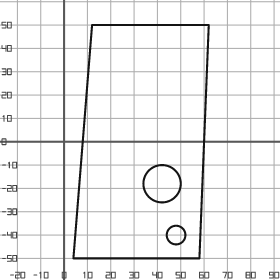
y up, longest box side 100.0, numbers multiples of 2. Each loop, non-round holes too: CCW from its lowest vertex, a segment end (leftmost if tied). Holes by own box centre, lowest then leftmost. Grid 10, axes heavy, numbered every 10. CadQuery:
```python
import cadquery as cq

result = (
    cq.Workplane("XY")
    .moveTo(4.0, -50.0)
    .lineTo(58.0, -50.0)
    .lineTo(62.0, 50.0)
    .lineTo(12.0, 50.0)
    .close()
    .moveTo(48.0, -40.0)
    .circle(4.0)
    .moveTo(42.0, -18.0)
    .circle(8.0)
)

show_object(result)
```